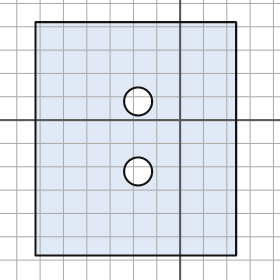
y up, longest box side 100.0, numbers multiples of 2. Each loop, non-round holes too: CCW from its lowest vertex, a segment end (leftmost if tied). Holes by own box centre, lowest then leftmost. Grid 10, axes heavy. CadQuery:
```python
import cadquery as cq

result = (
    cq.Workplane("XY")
    .moveTo(-62.0, -58.0)
    .lineTo(24.0, -58.0)
    .lineTo(24.0, 42.0)
    .lineTo(-62.0, 42.0)
    .close()
    .moveTo(-18.0, -22.0)
    .circle(6.0)
    .moveTo(-18.0, 8.0)
    .circle(6.0)
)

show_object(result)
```